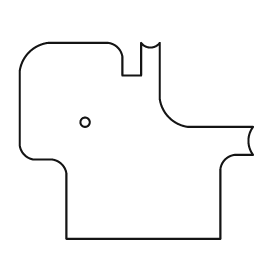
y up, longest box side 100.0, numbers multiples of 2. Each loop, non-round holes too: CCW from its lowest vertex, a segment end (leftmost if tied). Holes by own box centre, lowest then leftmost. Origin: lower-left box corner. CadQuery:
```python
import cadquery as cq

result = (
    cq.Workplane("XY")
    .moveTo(20.0, 0.0)
    .lineTo(86.0, 0.0)
    .lineTo(86.0, 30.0)
    .threePointArc((88.0, 34.0), (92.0, 36.0))
    .lineTo(100.0, 36.0)
    .threePointArc((98.0, 42.0), (100.0, 48.0))
    .lineTo(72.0, 48.0)
    .threePointArc((64.0, 52.0), (60.0, 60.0))
    .lineTo(60.0, 84.0)
    .threePointArc((56.0, 82.0), (52.0, 84.0))
    .lineTo(52.0, 70.0)
    .lineTo(44.0, 70.0)
    .lineTo(44.0, 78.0)
    .threePointArc((42.0, 82.0), (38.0, 84.0))
    .lineTo(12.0, 84.0)
    .threePointArc((4.0, 80.0), (0.0, 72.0))
    .lineTo(0.0, 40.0)
    .threePointArc((2.0, 36.0), (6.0, 34.0))
    .lineTo(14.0, 34.0)
    .threePointArc((18.0, 32.0), (20.0, 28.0))
    .close()
    .moveTo(28.0, 50.0)
    .circle(2.0)
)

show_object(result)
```